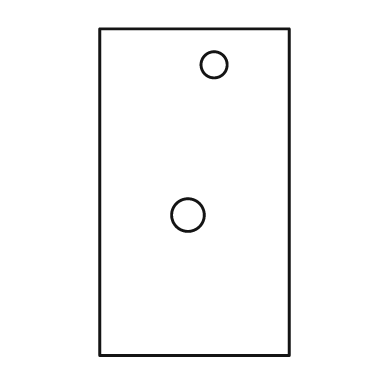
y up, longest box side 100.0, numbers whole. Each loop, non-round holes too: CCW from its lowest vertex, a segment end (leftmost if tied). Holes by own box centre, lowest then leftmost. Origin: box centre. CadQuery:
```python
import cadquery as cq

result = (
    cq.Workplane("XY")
    .moveTo(-29.0, -50.0)
    .lineTo(29.0, -50.0)
    .lineTo(29.0, 50.0)
    .lineTo(-29.0, 50.0)
    .close()
    .moveTo(-2.0, -7.0)
    .circle(5.0)
    .moveTo(6.0, 39.0)
    .circle(4.0)
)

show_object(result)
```